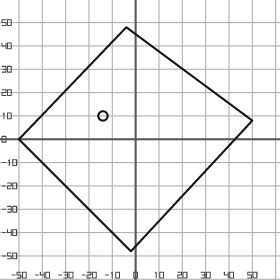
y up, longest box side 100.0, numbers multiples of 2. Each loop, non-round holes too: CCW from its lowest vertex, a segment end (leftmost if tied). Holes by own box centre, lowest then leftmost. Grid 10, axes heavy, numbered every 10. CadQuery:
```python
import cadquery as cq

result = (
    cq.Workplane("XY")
    .moveTo(-2.0, -48.0)
    .lineTo(50.0, 8.0)
    .lineTo(-4.0, 48.0)
    .lineTo(-50.0, 0.0)
    .close()
    .moveTo(-14.0, 10.0)
    .circle(2.0)
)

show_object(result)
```